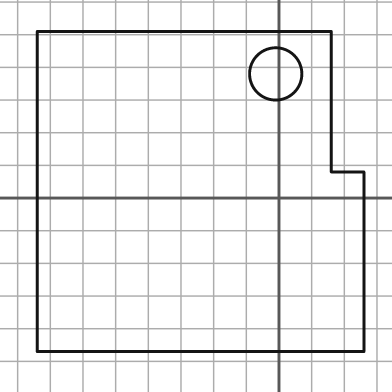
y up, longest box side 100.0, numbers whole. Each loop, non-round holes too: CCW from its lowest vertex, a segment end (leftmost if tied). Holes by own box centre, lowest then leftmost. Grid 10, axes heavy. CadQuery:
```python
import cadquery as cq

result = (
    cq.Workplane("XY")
    .moveTo(-74.0, -47.0)
    .lineTo(26.0, -47.0)
    .lineTo(26.0, 8.0)
    .lineTo(16.0, 8.0)
    .lineTo(16.0, 51.0)
    .lineTo(-74.0, 51.0)
    .close()
    .moveTo(-1.0, 38.0)
    .circle(8.0)
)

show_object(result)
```